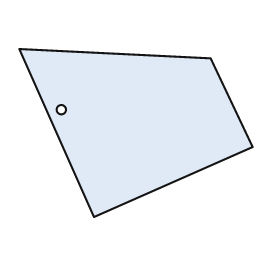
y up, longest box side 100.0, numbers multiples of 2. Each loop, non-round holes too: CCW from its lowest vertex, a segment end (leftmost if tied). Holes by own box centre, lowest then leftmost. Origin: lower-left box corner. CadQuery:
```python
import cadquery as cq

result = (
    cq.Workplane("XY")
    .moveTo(32.0, 0.0)
    .lineTo(100.0, 30.0)
    .lineTo(82.0, 68.0)
    .lineTo(0.0, 72.0)
    .close()
    .moveTo(18.0, 46.0)
    .circle(2.0)
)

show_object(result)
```